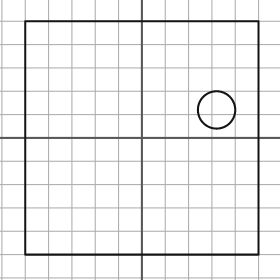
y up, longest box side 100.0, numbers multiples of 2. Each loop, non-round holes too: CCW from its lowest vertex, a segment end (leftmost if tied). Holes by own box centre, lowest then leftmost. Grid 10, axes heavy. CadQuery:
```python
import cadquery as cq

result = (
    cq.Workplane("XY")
    .moveTo(-50.0, -50.0)
    .lineTo(50.0, -50.0)
    .lineTo(50.0, 50.0)
    .lineTo(-50.0, 50.0)
    .close()
    .moveTo(32.0, 12.0)
    .circle(8.0)
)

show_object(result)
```